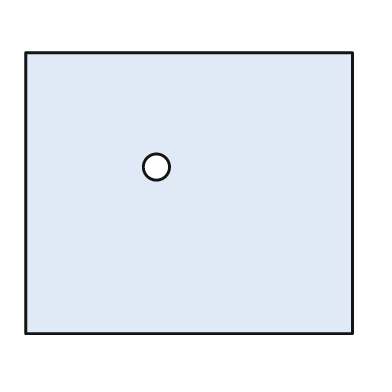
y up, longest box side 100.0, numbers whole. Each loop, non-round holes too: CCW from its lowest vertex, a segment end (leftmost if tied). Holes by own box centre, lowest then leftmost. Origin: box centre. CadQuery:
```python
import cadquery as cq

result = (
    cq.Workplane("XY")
    .moveTo(-50.0, -43.0)
    .lineTo(50.0, -43.0)
    .lineTo(50.0, 43.0)
    .lineTo(-50.0, 43.0)
    .close()
    .moveTo(-10.0, 8.0)
    .circle(4.0)
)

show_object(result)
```